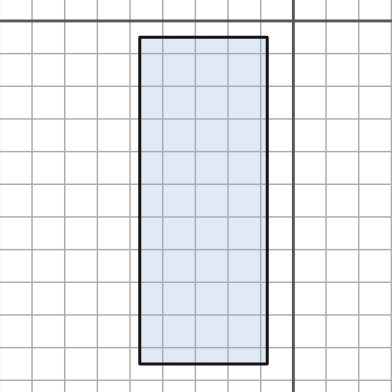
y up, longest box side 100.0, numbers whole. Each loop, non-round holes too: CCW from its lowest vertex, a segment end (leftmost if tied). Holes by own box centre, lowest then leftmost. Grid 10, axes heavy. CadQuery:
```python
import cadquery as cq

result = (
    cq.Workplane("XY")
    .moveTo(-47.0, -105.0)
    .lineTo(-8.0, -105.0)
    .lineTo(-8.0, -5.0)
    .lineTo(-47.0, -5.0)
    .close()
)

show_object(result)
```